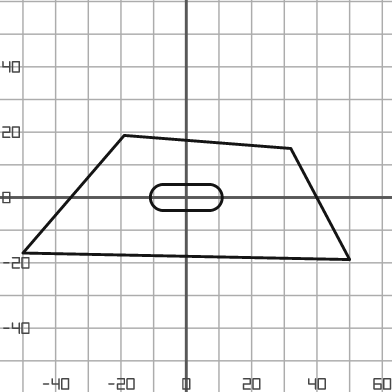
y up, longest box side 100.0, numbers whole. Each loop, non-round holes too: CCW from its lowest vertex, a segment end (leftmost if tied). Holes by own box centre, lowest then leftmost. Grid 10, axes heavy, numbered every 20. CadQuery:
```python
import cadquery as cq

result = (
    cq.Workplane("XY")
    .moveTo(50.0, -19.0)
    .lineTo(32.0, 15.0)
    .lineTo(-19.0, 19.0)
    .lineTo(-50.0, -17.0)
    .close()
    .moveTo(-7.0, -4.0)
    .lineTo(7.0, -4.0)
    .threePointArc((11.0, 0.0), (7.0, 4.0))
    .lineTo(-7.0, 4.0)
    .threePointArc((-11.0, 0.0), (-7.0, -4.0))
    .close()
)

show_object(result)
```